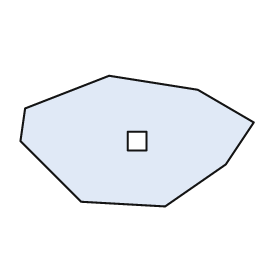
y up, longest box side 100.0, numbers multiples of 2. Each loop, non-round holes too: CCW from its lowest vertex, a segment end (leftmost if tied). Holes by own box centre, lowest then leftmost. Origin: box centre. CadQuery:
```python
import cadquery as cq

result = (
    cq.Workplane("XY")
    .moveTo(12.0, -28.0)
    .lineTo(38.0, -10.0)
    .lineTo(50.0, 8.0)
    .lineTo(26.0, 22.0)
    .lineTo(-12.0, 28.0)
    .lineTo(-48.0, 14.0)
    .lineTo(-50.0, 0.0)
    .lineTo(-24.0, -26.0)
    .close()
    .moveTo(-4.0, -4.0)
    .lineTo(4.0, -4.0)
    .lineTo(4.0, 4.0)
    .lineTo(-4.0, 4.0)
    .close()
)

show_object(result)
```